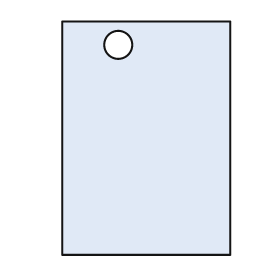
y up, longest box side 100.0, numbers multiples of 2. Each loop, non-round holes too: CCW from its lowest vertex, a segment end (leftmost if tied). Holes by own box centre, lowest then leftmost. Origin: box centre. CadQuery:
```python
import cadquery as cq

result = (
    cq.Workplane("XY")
    .moveTo(-36.0, -50.0)
    .lineTo(36.0, -50.0)
    .lineTo(36.0, 50.0)
    .lineTo(-36.0, 50.0)
    .close()
    .moveTo(-12.0, 40.0)
    .circle(6.0)
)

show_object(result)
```